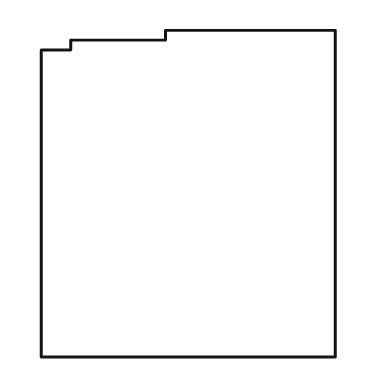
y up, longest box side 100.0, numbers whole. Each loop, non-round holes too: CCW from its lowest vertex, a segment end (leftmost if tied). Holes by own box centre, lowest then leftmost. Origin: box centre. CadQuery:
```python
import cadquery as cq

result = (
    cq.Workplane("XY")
    .moveTo(-45.0, -50.0)
    .lineTo(45.0, -50.0)
    .lineTo(45.0, 50.0)
    .lineTo(-7.0, 50.0)
    .lineTo(-7.0, 47.0)
    .lineTo(-36.0, 47.0)
    .lineTo(-36.0, 44.0)
    .lineTo(-45.0, 44.0)
    .close()
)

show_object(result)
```